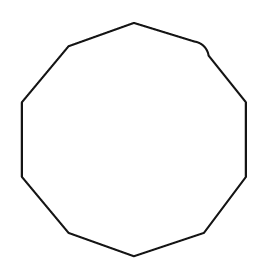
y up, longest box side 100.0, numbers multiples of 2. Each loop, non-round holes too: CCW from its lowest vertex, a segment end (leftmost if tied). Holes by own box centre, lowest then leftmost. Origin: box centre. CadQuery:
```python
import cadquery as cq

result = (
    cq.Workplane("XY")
    .moveTo(0.0, -50.0)
    .lineTo(30.0, -40.0)
    .lineTo(48.0, -16.0)
    .lineTo(48.0, 16.0)
    .lineTo(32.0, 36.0)
    .threePointArc((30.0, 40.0), (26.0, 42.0))
    .lineTo(0.0, 50.0)
    .lineTo(-28.0, 40.0)
    .lineTo(-48.0, 16.0)
    .lineTo(-48.0, -16.0)
    .lineTo(-28.0, -40.0)
    .close()
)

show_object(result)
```